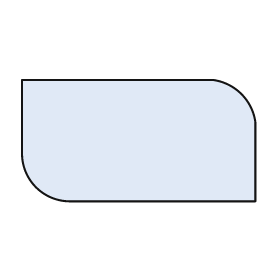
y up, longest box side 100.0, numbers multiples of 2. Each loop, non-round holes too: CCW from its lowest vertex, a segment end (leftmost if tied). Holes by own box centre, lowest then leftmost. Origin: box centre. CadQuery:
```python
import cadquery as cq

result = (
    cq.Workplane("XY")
    .moveTo(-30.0, -26.0)
    .lineTo(50.0, -26.0)
    .lineTo(50.0, 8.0)
    .threePointArc((44.0, 20.0), (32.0, 26.0))
    .lineTo(-50.0, 26.0)
    .lineTo(-50.0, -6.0)
    .threePointArc((-44.0, -20.0), (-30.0, -26.0))
    .close()
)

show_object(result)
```